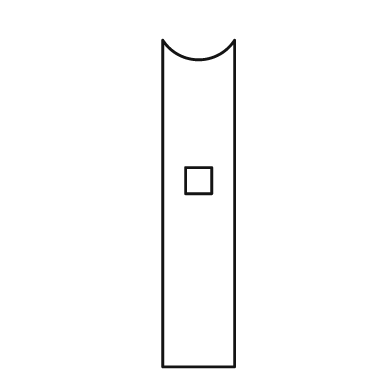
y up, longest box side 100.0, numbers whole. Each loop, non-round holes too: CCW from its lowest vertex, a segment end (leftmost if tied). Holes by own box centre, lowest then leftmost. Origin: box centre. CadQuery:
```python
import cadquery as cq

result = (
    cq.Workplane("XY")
    .moveTo(-11.0, -50.0)
    .lineTo(11.0, -50.0)
    .lineTo(11.0, 50.0)
    .threePointArc((0.0, 44.0), (-11.0, 50.0))
    .close()
    .moveTo(-4.0, 3.0)
    .lineTo(4.0, 3.0)
    .lineTo(4.0, 11.0)
    .lineTo(-4.0, 11.0)
    .close()
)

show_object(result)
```